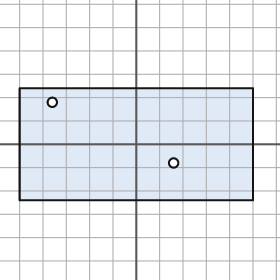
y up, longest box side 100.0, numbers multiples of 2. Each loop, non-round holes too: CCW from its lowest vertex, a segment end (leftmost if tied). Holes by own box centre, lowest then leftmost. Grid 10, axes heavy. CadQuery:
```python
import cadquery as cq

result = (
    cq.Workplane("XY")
    .moveTo(-50.0, -24.0)
    .lineTo(50.0, -24.0)
    .lineTo(50.0, 24.0)
    .lineTo(-50.0, 24.0)
    .close()
    .moveTo(16.0, -8.0)
    .circle(2.0)
    .moveTo(-36.0, 18.0)
    .circle(2.0)
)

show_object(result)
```